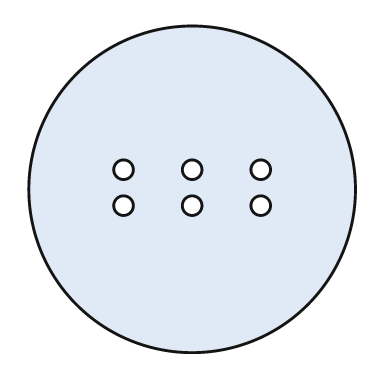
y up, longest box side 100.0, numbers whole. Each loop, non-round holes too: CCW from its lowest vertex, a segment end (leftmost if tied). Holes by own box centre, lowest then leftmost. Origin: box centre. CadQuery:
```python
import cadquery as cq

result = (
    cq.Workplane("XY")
    .moveTo(0.0, 0.0)
    .circle(50.0)
    .moveTo(-21.0, -5.0)
    .circle(3.0)
    .moveTo(0.0, -5.0)
    .circle(3.0)
    .moveTo(21.0, -5.0)
    .circle(3.0)
    .moveTo(-21.0, 6.0)
    .circle(3.0)
    .moveTo(0.0, 6.0)
    .circle(3.0)
    .moveTo(21.0, 6.0)
    .circle(3.0)
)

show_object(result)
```